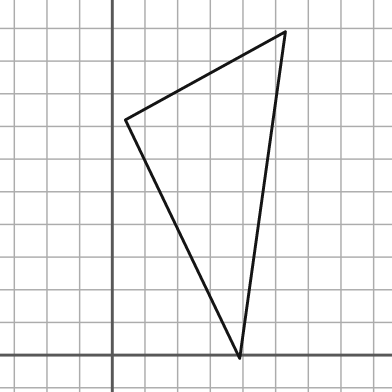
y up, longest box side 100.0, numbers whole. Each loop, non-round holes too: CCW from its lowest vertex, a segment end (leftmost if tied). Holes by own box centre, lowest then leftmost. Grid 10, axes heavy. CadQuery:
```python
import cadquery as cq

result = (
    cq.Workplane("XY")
    .moveTo(39.0, -1.0)
    .lineTo(53.0, 99.0)
    .lineTo(4.0, 72.0)
    .close()
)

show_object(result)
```